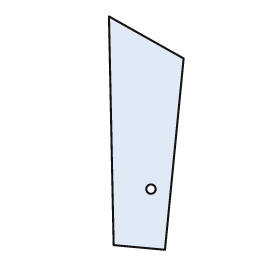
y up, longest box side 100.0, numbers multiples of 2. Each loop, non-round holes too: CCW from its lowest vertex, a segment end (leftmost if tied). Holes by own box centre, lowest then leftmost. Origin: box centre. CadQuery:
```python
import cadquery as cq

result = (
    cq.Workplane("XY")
    .moveTo(8.0, -50.0)
    .lineTo(16.0, 32.0)
    .lineTo(-16.0, 50.0)
    .lineTo(-14.0, -48.0)
    .close()
    .moveTo(2.0, -24.0)
    .circle(2.0)
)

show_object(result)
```